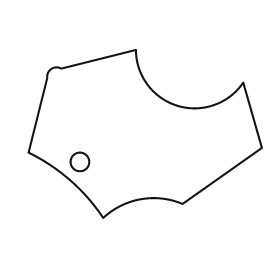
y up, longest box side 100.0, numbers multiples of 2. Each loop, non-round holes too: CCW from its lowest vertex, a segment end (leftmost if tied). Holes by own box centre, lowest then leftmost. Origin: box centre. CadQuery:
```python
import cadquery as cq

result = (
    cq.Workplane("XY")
    .moveTo(-18.0, -36.0)
    .threePointArc((-2.0, -28.0), (16.0, -30.0))
    .lineTo(50.0, -6.0)
    .lineTo(42.0, 22.0)
    .threePointArc((14.0, 12.0), (-4.0, 36.0))
    .lineTo(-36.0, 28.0)
    .threePointArc((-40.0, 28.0), (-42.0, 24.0))
    .lineTo(-50.0, -8.0)
    .threePointArc((-32.0, -20.0), (-18.0, -36.0))
    .close()
    .moveTo(-28.0, -12.0)
    .circle(4.0)
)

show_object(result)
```